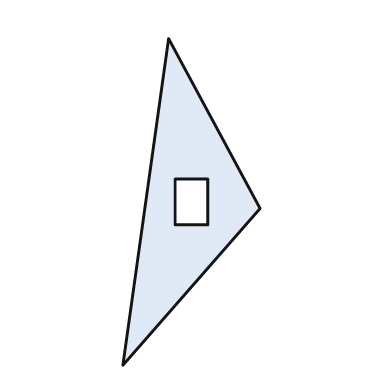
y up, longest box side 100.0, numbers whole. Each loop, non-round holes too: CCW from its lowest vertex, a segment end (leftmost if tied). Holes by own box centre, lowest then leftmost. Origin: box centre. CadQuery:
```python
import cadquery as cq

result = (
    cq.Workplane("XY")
    .moveTo(-21.0, -50.0)
    .lineTo(21.0, -2.0)
    .lineTo(-7.0, 50.0)
    .close()
    .moveTo(-5.0, -7.0)
    .lineTo(5.0, -7.0)
    .lineTo(5.0, 7.0)
    .lineTo(-5.0, 7.0)
    .close()
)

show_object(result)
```